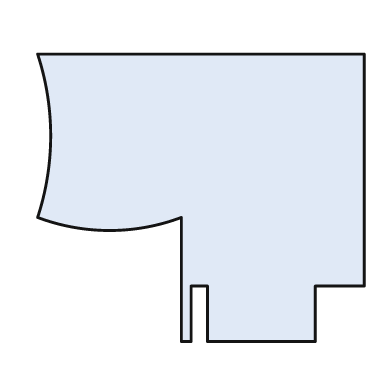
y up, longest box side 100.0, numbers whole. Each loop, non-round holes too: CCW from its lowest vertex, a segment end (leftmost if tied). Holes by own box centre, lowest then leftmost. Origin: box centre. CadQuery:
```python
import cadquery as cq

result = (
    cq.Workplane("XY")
    .moveTo(-6.0, -44.0)
    .lineTo(-3.0, -44.0)
    .lineTo(-3.0, -27.0)
    .lineTo(2.0, -27.0)
    .lineTo(2.0, -44.0)
    .lineTo(35.0, -44.0)
    .lineTo(35.0, -27.0)
    .lineTo(50.0, -27.0)
    .lineTo(50.0, 44.0)
    .lineTo(-50.0, 44.0)
    .threePointArc((-46.0, 19.0), (-50.0, -6.0))
    .threePointArc((-28.0, -10.0), (-6.0, -6.0))
    .close()
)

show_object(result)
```